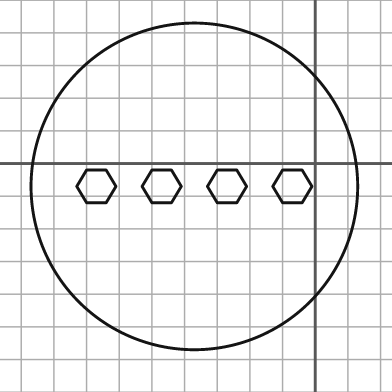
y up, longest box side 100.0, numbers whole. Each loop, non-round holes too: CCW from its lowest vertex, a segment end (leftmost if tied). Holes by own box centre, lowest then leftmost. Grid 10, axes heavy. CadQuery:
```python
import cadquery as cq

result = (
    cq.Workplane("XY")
    .moveTo(-37.0, -7.0)
    .circle(50.0)
    .moveTo(-70.0, -12.0)
    .lineTo(-64.0, -12.0)
    .lineTo(-61.0, -7.0)
    .lineTo(-64.0, -2.0)
    .lineTo(-70.0, -2.0)
    .lineTo(-73.0, -7.0)
    .close()
    .moveTo(-50.0, -12.0)
    .lineTo(-44.0, -12.0)
    .lineTo(-41.0, -7.0)
    .lineTo(-44.0, -2.0)
    .lineTo(-50.0, -2.0)
    .lineTo(-53.0, -7.0)
    .close()
    .moveTo(-30.0, -12.0)
    .lineTo(-24.0, -12.0)
    .lineTo(-21.0, -7.0)
    .lineTo(-24.0, -2.0)
    .lineTo(-30.0, -2.0)
    .lineTo(-33.0, -7.0)
    .close()
    .moveTo(-10.0, -12.0)
    .lineTo(-4.0, -12.0)
    .lineTo(-1.0, -7.0)
    .lineTo(-4.0, -2.0)
    .lineTo(-10.0, -2.0)
    .lineTo(-13.0, -7.0)
    .close()
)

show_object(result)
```